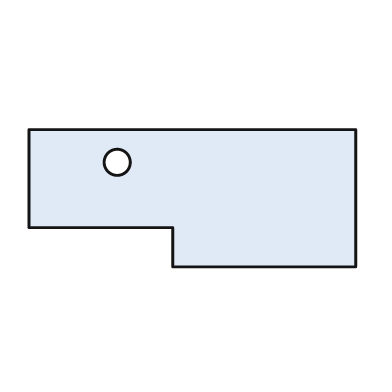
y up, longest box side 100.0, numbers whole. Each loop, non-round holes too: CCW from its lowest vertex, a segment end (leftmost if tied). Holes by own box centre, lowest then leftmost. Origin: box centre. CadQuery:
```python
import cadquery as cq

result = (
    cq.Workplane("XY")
    .moveTo(-6.0, -21.0)
    .lineTo(50.0, -21.0)
    .lineTo(50.0, 21.0)
    .lineTo(-50.0, 21.0)
    .lineTo(-50.0, -9.0)
    .lineTo(-6.0, -9.0)
    .close()
    .moveTo(-23.0, 11.0)
    .circle(4.0)
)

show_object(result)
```